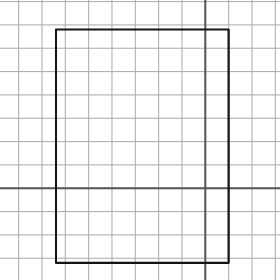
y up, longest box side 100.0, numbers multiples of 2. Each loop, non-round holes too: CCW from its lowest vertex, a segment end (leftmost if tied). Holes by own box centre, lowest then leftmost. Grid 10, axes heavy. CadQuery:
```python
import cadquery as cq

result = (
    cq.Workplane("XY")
    .moveTo(-64.0, -32.0)
    .lineTo(10.0, -32.0)
    .lineTo(10.0, 68.0)
    .lineTo(-64.0, 68.0)
    .close()
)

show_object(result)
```